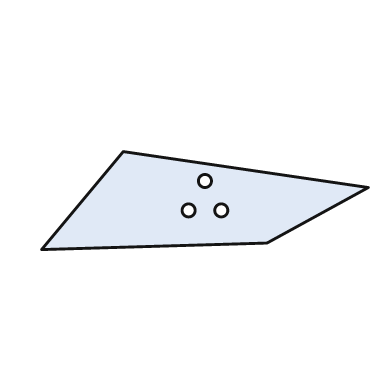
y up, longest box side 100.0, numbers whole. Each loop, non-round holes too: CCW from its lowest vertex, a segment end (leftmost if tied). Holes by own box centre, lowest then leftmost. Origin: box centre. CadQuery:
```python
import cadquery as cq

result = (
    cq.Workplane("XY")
    .moveTo(-50.0, -15.0)
    .lineTo(19.0, -13.0)
    .lineTo(50.0, 4.0)
    .lineTo(-25.0, 15.0)
    .close()
    .moveTo(-5.0, -3.0)
    .circle(2.0)
    .moveTo(5.0, -3.0)
    .circle(2.0)
    .moveTo(0.0, 6.0)
    .circle(2.0)
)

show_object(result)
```